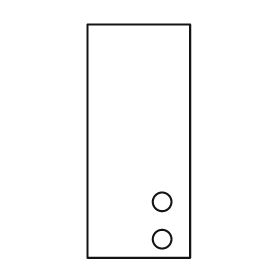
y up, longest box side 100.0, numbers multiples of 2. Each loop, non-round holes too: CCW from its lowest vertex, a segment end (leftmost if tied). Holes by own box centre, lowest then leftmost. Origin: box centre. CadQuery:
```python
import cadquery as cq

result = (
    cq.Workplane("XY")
    .moveTo(-22.0, -50.0)
    .lineTo(22.0, -50.0)
    .lineTo(22.0, 50.0)
    .lineTo(-22.0, 50.0)
    .close()
    .moveTo(10.0, -42.0)
    .circle(4.0)
    .moveTo(10.0, -26.0)
    .circle(4.0)
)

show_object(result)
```